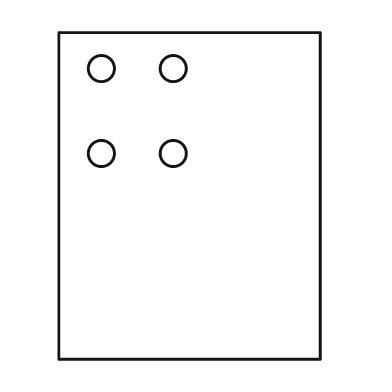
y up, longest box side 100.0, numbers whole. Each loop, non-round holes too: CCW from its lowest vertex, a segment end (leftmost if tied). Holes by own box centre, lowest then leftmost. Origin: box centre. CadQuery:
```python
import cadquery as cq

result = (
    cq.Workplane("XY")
    .moveTo(-40.0, -50.0)
    .lineTo(40.0, -50.0)
    .lineTo(40.0, 50.0)
    .lineTo(-40.0, 50.0)
    .close()
    .moveTo(-27.0, 13.0)
    .circle(4.0)
    .moveTo(-5.0, 13.0)
    .circle(4.0)
    .moveTo(-27.0, 39.0)
    .circle(4.0)
    .moveTo(-5.0, 39.0)
    .circle(4.0)
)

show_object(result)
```